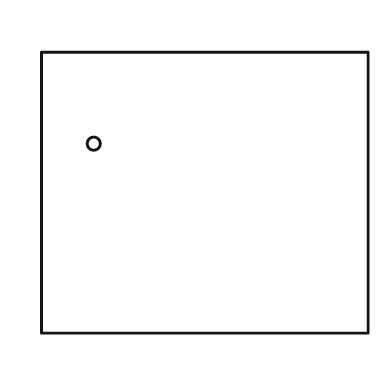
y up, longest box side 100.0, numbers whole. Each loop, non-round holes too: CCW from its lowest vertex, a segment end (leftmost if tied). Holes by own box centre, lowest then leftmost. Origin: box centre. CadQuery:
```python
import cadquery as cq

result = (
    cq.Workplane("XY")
    .moveTo(-50.0, -43.0)
    .lineTo(50.0, -43.0)
    .lineTo(50.0, 43.0)
    .lineTo(-50.0, 43.0)
    .close()
    .moveTo(-34.0, 15.0)
    .circle(2.0)
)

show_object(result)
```